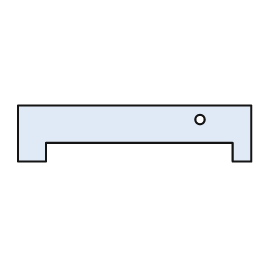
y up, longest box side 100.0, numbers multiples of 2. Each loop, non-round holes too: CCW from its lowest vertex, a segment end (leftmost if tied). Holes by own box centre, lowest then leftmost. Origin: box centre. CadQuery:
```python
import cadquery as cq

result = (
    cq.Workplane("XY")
    .moveTo(-50.0, -12.0)
    .lineTo(-38.0, -12.0)
    .lineTo(-38.0, -4.0)
    .lineTo(42.0, -4.0)
    .lineTo(42.0, -12.0)
    .lineTo(50.0, -12.0)
    .lineTo(50.0, 12.0)
    .lineTo(-50.0, 12.0)
    .close()
    .moveTo(28.0, 6.0)
    .circle(2.0)
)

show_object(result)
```